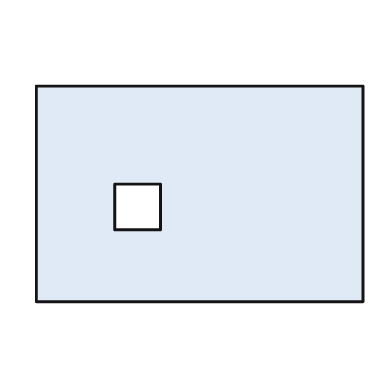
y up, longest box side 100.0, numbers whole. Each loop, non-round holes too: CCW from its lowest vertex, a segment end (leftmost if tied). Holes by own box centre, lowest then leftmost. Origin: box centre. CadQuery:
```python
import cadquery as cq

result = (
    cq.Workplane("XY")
    .moveTo(-50.0, -33.0)
    .lineTo(50.0, -33.0)
    .lineTo(50.0, 33.0)
    .lineTo(-50.0, 33.0)
    .close()
    .moveTo(-26.0, -11.0)
    .lineTo(-12.0, -11.0)
    .lineTo(-12.0, 3.0)
    .lineTo(-26.0, 3.0)
    .close()
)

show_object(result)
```